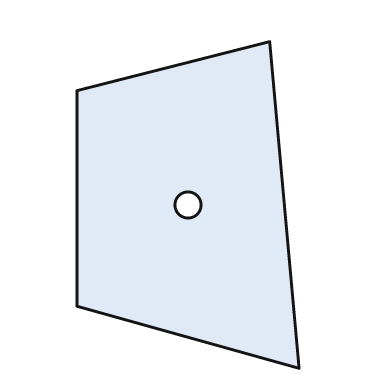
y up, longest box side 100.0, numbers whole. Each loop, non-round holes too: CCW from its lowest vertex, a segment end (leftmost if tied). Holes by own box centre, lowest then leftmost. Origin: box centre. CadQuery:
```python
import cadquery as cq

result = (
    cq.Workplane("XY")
    .moveTo(34.0, -50.0)
    .lineTo(25.0, 50.0)
    .lineTo(-34.0, 35.0)
    .lineTo(-34.0, -31.0)
    .close()
    .moveTo(0.0, 0.0)
    .circle(4.0)
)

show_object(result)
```